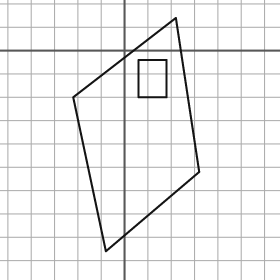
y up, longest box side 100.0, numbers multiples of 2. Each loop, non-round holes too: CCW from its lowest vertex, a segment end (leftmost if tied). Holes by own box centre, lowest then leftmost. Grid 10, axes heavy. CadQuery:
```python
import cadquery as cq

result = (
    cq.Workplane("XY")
    .moveTo(-8.0, -86.0)
    .lineTo(32.0, -52.0)
    .lineTo(22.0, 14.0)
    .lineTo(-22.0, -20.0)
    .close()
    .moveTo(6.0, -20.0)
    .lineTo(18.0, -20.0)
    .lineTo(18.0, -4.0)
    .lineTo(6.0, -4.0)
    .close()
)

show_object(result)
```